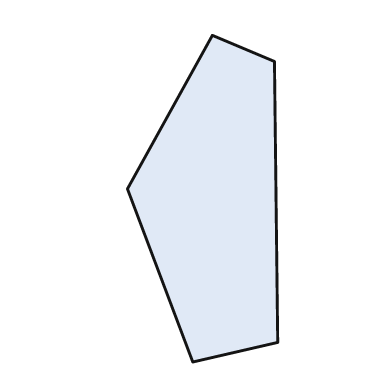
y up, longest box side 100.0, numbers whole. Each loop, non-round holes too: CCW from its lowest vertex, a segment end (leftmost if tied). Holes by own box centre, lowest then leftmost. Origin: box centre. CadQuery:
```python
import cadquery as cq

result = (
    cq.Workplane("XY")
    .moveTo(-3.0, -50.0)
    .lineTo(23.0, -44.0)
    .lineTo(22.0, 42.0)
    .lineTo(3.0, 50.0)
    .lineTo(-23.0, 3.0)
    .close()
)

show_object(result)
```